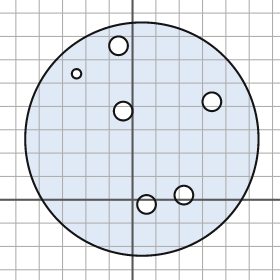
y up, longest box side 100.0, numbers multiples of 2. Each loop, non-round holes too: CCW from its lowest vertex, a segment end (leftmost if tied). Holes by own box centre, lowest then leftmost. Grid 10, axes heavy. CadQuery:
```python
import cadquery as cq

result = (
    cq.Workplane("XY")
    .moveTo(4.0, 26.0)
    .circle(50.0)
    .moveTo(6.0, -2.0)
    .circle(4.0)
    .moveTo(22.0, 2.0)
    .circle(4.0)
    .moveTo(-4.0, 38.0)
    .circle(4.0)
    .moveTo(34.0, 42.0)
    .circle(4.0)
    .moveTo(-24.0, 54.0)
    .circle(2.0)
    .moveTo(-6.0, 66.0)
    .circle(4.0)
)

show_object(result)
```